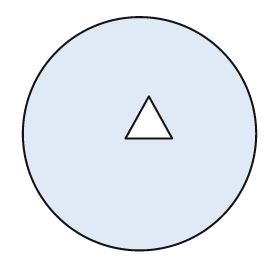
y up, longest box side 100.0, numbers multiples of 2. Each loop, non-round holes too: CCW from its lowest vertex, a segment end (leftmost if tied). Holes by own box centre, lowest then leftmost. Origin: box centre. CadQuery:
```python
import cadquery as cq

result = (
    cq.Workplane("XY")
    .moveTo(0.0, 0.0)
    .circle(50.0)
    .moveTo(-6.0, -2.0)
    .lineTo(14.0, -2.0)
    .lineTo(4.0, 16.0)
    .close()
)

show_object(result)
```